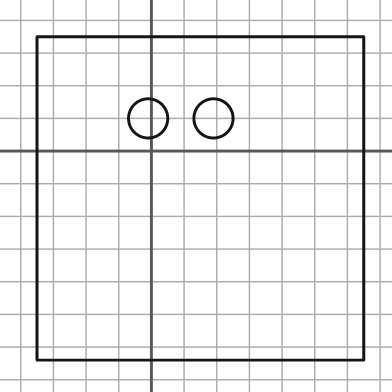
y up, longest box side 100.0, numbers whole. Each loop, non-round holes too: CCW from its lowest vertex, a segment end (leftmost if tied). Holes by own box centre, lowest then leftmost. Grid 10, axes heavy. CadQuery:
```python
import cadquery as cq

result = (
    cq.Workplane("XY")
    .moveTo(-35.0, -64.0)
    .lineTo(65.0, -64.0)
    .lineTo(65.0, 35.0)
    .lineTo(-35.0, 35.0)
    .close()
    .moveTo(-1.0, 10.0)
    .circle(6.0)
    .moveTo(19.0, 10.0)
    .circle(6.0)
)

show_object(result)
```